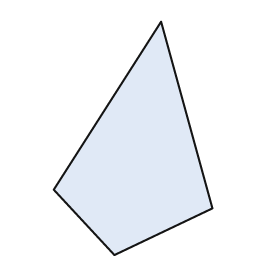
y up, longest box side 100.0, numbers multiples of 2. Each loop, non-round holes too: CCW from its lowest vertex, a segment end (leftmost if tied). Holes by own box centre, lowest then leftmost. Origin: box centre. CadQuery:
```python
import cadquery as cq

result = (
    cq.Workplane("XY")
    .moveTo(-8.0, -50.0)
    .lineTo(34.0, -30.0)
    .lineTo(12.0, 50.0)
    .lineTo(-34.0, -22.0)
    .close()
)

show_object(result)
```